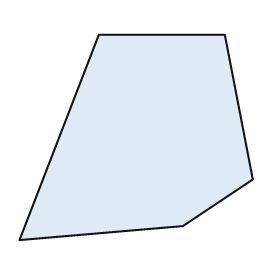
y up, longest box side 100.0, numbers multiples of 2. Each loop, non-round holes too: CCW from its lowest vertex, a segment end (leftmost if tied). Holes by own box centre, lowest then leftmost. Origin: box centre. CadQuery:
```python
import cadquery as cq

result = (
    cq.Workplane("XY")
    .moveTo(-50.0, -44.0)
    .lineTo(20.0, -38.0)
    .lineTo(50.0, -18.0)
    .lineTo(38.0, 44.0)
    .lineTo(-16.0, 44.0)
    .close()
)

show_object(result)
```